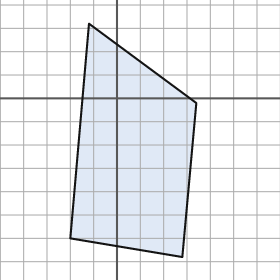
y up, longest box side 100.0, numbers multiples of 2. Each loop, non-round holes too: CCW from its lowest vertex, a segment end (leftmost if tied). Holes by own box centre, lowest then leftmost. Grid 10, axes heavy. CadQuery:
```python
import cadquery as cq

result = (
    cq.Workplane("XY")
    .moveTo(28.0, -68.0)
    .lineTo(34.0, -2.0)
    .lineTo(-12.0, 32.0)
    .lineTo(-20.0, -60.0)
    .close()
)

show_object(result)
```